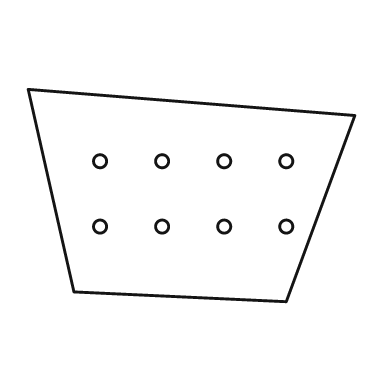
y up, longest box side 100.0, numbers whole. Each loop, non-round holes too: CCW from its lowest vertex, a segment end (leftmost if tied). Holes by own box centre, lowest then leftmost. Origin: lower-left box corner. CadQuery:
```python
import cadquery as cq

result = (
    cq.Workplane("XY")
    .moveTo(79.0, 0.0)
    .lineTo(100.0, 57.0)
    .lineTo(0.0, 65.0)
    .lineTo(14.0, 3.0)
    .close()
    .moveTo(22.0, 23.0)
    .circle(2.0)
    .moveTo(41.0, 23.0)
    .circle(2.0)
    .moveTo(60.0, 23.0)
    .circle(2.0)
    .moveTo(79.0, 23.0)
    .circle(2.0)
    .moveTo(22.0, 43.0)
    .circle(2.0)
    .moveTo(41.0, 43.0)
    .circle(2.0)
    .moveTo(60.0, 43.0)
    .circle(2.0)
    .moveTo(79.0, 43.0)
    .circle(2.0)
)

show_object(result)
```